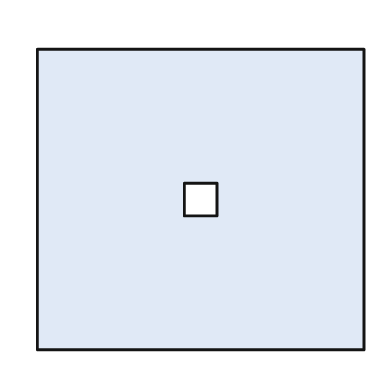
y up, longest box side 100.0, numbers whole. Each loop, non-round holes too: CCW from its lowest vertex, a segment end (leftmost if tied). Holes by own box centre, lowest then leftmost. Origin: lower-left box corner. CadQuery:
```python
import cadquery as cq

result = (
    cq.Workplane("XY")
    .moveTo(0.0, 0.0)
    .lineTo(100.0, 0.0)
    .lineTo(100.0, 92.0)
    .lineTo(0.0, 92.0)
    .close()
    .moveTo(45.0, 41.0)
    .lineTo(55.0, 41.0)
    .lineTo(55.0, 51.0)
    .lineTo(45.0, 51.0)
    .close()
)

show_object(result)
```